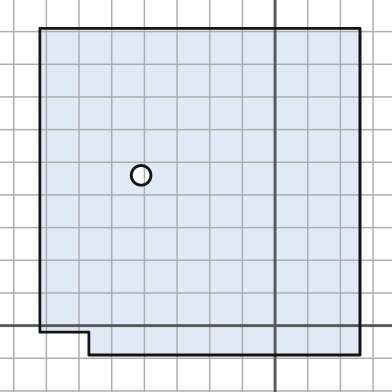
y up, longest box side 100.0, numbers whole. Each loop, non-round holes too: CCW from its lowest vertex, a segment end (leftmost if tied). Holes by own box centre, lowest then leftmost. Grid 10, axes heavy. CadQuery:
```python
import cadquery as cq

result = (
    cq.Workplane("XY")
    .moveTo(-57.0, -9.0)
    .lineTo(26.0, -9.0)
    .lineTo(26.0, 91.0)
    .lineTo(-72.0, 91.0)
    .lineTo(-72.0, -2.0)
    .lineTo(-57.0, -2.0)
    .close()
    .moveTo(-41.0, 46.0)
    .circle(3.0)
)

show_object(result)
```